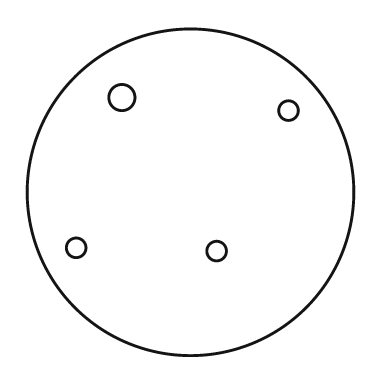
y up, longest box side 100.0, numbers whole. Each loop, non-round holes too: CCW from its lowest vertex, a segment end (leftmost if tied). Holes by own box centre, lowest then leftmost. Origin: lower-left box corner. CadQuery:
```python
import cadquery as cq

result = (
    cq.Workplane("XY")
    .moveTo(50.0, 50.0)
    .circle(50.0)
    .moveTo(58.0, 32.0)
    .circle(3.0)
    .moveTo(15.0, 33.0)
    .circle(3.0)
    .moveTo(80.0, 75.0)
    .circle(3.0)
    .moveTo(29.0, 79.0)
    .circle(4.0)
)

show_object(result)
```